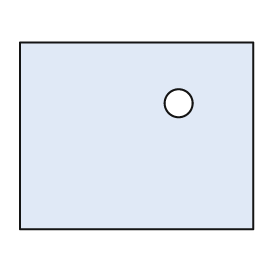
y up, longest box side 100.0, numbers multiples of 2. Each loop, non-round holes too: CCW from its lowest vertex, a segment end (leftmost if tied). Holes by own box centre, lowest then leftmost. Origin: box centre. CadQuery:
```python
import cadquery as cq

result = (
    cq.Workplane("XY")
    .moveTo(-50.0, -40.0)
    .lineTo(50.0, -40.0)
    .lineTo(50.0, 40.0)
    .lineTo(-50.0, 40.0)
    .close()
    .moveTo(18.0, 14.0)
    .circle(6.0)
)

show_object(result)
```